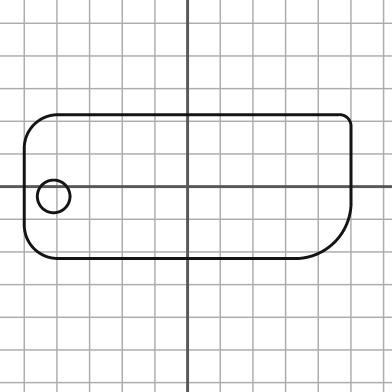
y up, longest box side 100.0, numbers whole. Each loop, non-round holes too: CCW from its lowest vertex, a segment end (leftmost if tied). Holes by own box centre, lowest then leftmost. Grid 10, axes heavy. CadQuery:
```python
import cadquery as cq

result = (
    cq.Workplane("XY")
    .moveTo(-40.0, -22.0)
    .lineTo(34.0, -22.0)
    .threePointArc((45.0, -17.0), (50.0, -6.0))
    .lineTo(50.0, 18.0)
    .threePointArc((49.0, 21.0), (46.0, 22.0))
    .lineTo(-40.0, 22.0)
    .threePointArc((-47.0, 19.0), (-50.0, 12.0))
    .lineTo(-50.0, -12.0)
    .threePointArc((-47.0, -19.0), (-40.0, -22.0))
    .close()
    .moveTo(-41.0, -3.0)
    .circle(5.0)
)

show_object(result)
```